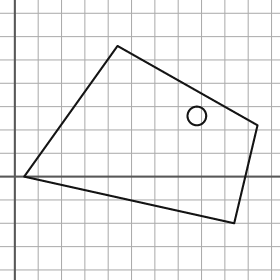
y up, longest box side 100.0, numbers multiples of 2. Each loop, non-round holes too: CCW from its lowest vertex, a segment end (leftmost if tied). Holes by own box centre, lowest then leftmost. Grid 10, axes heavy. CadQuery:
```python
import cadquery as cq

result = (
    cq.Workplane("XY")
    .moveTo(94.0, -20.0)
    .lineTo(104.0, 22.0)
    .lineTo(44.0, 56.0)
    .lineTo(4.0, 0.0)
    .close()
    .moveTo(78.0, 26.0)
    .circle(4.0)
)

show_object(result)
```